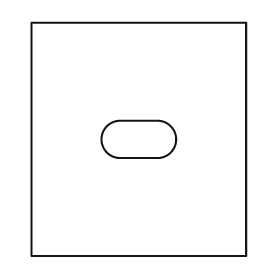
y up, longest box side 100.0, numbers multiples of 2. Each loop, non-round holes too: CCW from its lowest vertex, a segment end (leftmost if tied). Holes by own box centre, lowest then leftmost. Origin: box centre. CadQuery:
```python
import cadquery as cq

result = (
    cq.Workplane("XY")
    .moveTo(-46.0, -50.0)
    .lineTo(46.0, -50.0)
    .lineTo(46.0, 50.0)
    .lineTo(-46.0, 50.0)
    .close()
    .moveTo(-8.0, -8.0)
    .lineTo(8.0, -8.0)
    .threePointArc((16.0, 0.0), (8.0, 8.0))
    .lineTo(-8.0, 8.0)
    .threePointArc((-16.0, 0.0), (-8.0, -8.0))
    .close()
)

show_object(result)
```